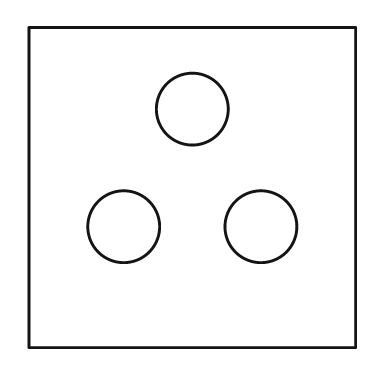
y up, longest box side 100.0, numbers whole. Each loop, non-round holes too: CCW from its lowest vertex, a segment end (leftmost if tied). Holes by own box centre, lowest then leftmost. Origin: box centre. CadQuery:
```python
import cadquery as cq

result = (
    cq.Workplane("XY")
    .moveTo(-50.0, -49.0)
    .lineTo(50.0, -49.0)
    .lineTo(50.0, 49.0)
    .lineTo(-50.0, 49.0)
    .close()
    .moveTo(-21.0, -12.0)
    .circle(11.0)
    .moveTo(21.0, -12.0)
    .circle(11.0)
    .moveTo(0.0, 24.0)
    .circle(11.0)
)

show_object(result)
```